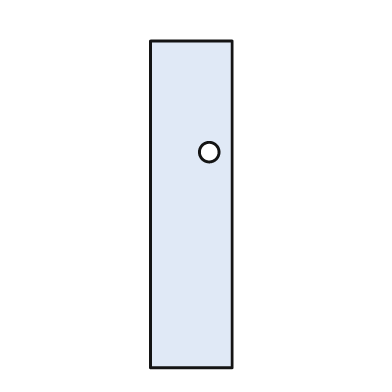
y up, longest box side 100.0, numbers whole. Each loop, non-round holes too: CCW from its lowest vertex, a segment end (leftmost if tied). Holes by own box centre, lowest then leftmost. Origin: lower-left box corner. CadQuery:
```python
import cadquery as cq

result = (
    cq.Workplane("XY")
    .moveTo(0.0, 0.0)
    .lineTo(25.0, 0.0)
    .lineTo(25.0, 100.0)
    .lineTo(0.0, 100.0)
    .close()
    .moveTo(18.0, 66.0)
    .circle(3.0)
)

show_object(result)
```